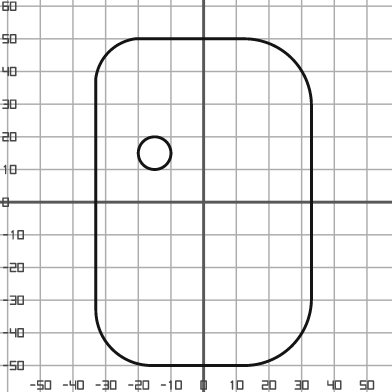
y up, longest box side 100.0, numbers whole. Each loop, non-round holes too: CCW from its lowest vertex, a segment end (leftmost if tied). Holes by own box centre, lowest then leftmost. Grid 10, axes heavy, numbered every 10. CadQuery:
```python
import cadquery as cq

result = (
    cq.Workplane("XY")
    .moveTo(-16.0, -50.0)
    .lineTo(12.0, -50.0)
    .threePointArc((27.0, -44.0), (33.0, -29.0))
    .lineTo(33.0, 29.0)
    .threePointArc((27.0, 44.0), (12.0, 50.0))
    .lineTo(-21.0, 50.0)
    .threePointArc((-29.0, 46.0), (-33.0, 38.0))
    .lineTo(-33.0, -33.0)
    .threePointArc((-28.0, -45.0), (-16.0, -50.0))
    .close()
    .moveTo(-15.0, 15.0)
    .circle(5.0)
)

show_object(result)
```